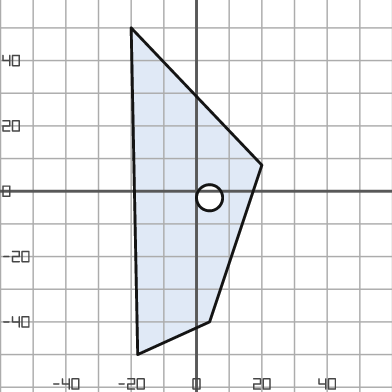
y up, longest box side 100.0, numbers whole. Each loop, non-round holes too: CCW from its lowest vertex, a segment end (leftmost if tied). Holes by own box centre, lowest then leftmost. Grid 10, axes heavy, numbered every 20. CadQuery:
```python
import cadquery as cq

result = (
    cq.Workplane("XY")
    .moveTo(-18.0, -50.0)
    .lineTo(4.0, -40.0)
    .lineTo(20.0, 8.0)
    .lineTo(-20.0, 50.0)
    .close()
    .moveTo(4.0, -2.0)
    .circle(4.0)
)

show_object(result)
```